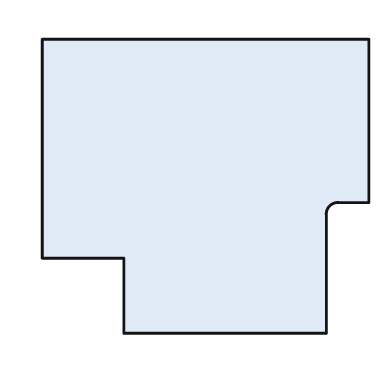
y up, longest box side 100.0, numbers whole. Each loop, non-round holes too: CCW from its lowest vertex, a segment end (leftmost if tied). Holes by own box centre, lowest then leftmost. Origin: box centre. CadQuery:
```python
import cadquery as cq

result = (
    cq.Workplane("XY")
    .moveTo(-25.0, -45.0)
    .lineTo(37.0, -45.0)
    .lineTo(37.0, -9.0)
    .threePointArc((38.0, -6.0), (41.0, -5.0))
    .lineTo(50.0, -5.0)
    .lineTo(50.0, 45.0)
    .lineTo(-50.0, 45.0)
    .lineTo(-50.0, -22.0)
    .lineTo(-25.0, -22.0)
    .close()
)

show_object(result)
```